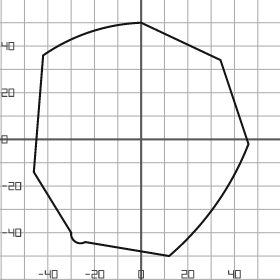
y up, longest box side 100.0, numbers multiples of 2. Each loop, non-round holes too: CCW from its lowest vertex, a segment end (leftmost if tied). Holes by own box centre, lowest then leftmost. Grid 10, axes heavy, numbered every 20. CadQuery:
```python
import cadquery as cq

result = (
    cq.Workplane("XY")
    .moveTo(12.0, -50.0)
    .threePointArc((32.0, -28.0), (46.0, -2.0))
    .lineTo(34.0, 34.0)
    .lineTo(0.0, 50.0)
    .threePointArc((-22.0, 46.0), (-42.0, 36.0))
    .lineTo(-46.0, -14.0)
    .lineTo(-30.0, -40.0)
    .threePointArc((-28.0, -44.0), (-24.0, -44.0))
    .close()
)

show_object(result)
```